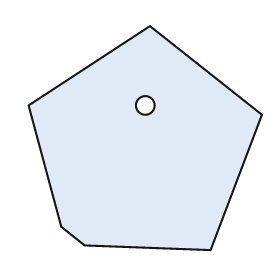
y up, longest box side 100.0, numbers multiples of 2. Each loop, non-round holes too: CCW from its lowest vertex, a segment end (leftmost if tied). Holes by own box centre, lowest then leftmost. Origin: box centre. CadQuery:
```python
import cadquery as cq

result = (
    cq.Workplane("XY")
    .moveTo(28.0, -48.0)
    .lineTo(50.0, 10.0)
    .lineTo(2.0, 48.0)
    .lineTo(-50.0, 14.0)
    .lineTo(-36.0, -38.0)
    .lineTo(-26.0, -46.0)
    .close()
    .moveTo(0.0, 14.0)
    .circle(4.0)
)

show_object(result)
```